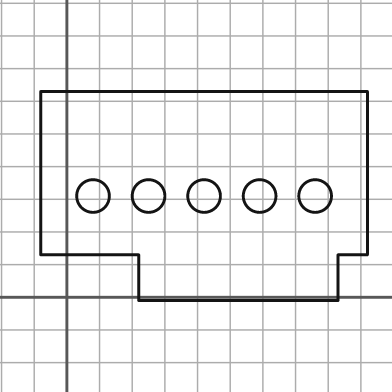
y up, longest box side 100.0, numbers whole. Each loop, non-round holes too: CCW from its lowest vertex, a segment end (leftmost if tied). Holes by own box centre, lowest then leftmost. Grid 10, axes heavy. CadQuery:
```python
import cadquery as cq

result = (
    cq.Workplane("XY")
    .moveTo(22.0, -1.0)
    .lineTo(83.0, -1.0)
    .lineTo(83.0, 13.0)
    .lineTo(92.0, 13.0)
    .lineTo(92.0, 63.0)
    .lineTo(-8.0, 63.0)
    .lineTo(-8.0, 13.0)
    .lineTo(22.0, 13.0)
    .close()
    .moveTo(8.0, 31.0)
    .circle(5.0)
    .moveTo(25.0, 31.0)
    .circle(5.0)
    .moveTo(42.0, 31.0)
    .circle(5.0)
    .moveTo(59.0, 31.0)
    .circle(5.0)
    .moveTo(76.0, 31.0)
    .circle(5.0)
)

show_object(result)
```